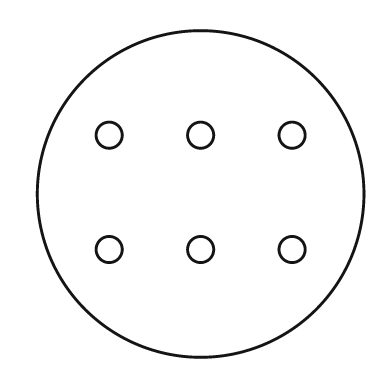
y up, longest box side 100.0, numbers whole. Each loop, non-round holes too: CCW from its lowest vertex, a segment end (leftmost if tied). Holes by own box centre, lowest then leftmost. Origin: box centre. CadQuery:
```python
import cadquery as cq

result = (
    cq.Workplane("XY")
    .moveTo(0.0, 0.0)
    .circle(50.0)
    .moveTo(-28.0, -17.0)
    .circle(4.0)
    .moveTo(0.0, -17.0)
    .circle(4.0)
    .moveTo(28.0, -17.0)
    .circle(4.0)
    .moveTo(-28.0, 18.0)
    .circle(4.0)
    .moveTo(0.0, 18.0)
    .circle(4.0)
    .moveTo(28.0, 18.0)
    .circle(4.0)
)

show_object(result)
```